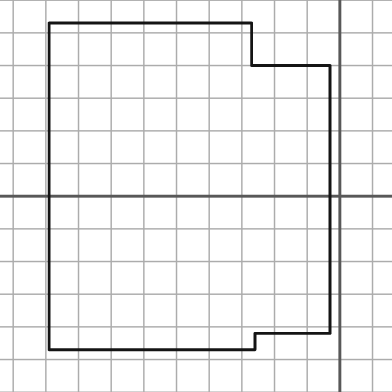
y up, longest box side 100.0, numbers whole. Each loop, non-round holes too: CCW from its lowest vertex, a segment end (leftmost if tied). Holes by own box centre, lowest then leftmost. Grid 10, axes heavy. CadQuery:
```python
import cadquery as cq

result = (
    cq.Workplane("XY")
    .moveTo(-89.0, -47.0)
    .lineTo(-26.0, -47.0)
    .lineTo(-26.0, -42.0)
    .lineTo(-3.0, -42.0)
    .lineTo(-3.0, 40.0)
    .lineTo(-27.0, 40.0)
    .lineTo(-27.0, 53.0)
    .lineTo(-89.0, 53.0)
    .close()
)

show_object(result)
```